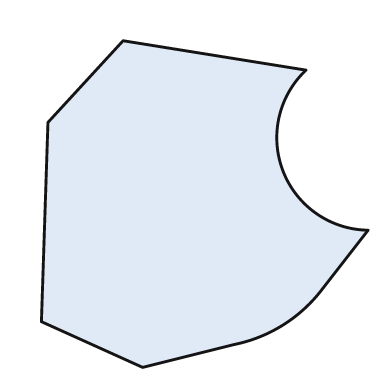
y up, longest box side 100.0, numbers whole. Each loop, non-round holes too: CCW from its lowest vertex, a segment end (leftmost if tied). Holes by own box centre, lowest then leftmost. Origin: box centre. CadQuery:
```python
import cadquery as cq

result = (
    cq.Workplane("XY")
    .moveTo(-19.0, -50.0)
    .lineTo(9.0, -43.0)
    .threePointArc((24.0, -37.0), (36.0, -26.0))
    .lineTo(50.0, -8.0)
    .threePointArc((24.0, 10.0), (31.0, 41.0))
    .lineTo(-25.0, 50.0)
    .lineTo(-48.0, 25.0)
    .lineTo(-50.0, -36.0)
    .close()
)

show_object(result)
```